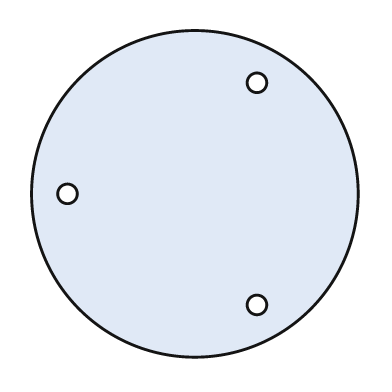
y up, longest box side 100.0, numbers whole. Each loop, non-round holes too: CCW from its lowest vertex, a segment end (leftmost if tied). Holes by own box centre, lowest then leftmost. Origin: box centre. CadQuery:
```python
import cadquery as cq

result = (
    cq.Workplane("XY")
    .moveTo(0.0, 0.0)
    .circle(50.0)
    .moveTo(19.0, -34.0)
    .circle(3.0)
    .moveTo(-39.0, 0.0)
    .circle(3.0)
    .moveTo(19.0, 34.0)
    .circle(3.0)
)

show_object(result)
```